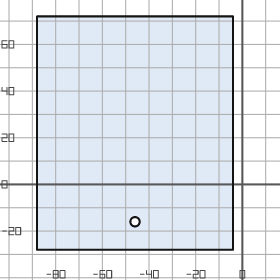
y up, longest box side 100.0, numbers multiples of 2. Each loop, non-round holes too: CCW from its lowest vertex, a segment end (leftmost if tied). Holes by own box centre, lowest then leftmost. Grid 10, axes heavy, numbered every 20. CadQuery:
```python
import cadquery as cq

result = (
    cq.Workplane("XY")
    .moveTo(-88.0, -28.0)
    .lineTo(-4.0, -28.0)
    .lineTo(-4.0, 72.0)
    .lineTo(-88.0, 72.0)
    .close()
    .moveTo(-46.0, -16.0)
    .circle(2.0)
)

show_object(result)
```